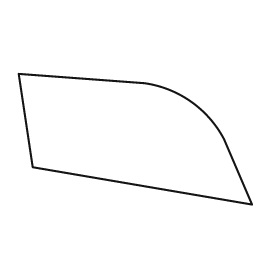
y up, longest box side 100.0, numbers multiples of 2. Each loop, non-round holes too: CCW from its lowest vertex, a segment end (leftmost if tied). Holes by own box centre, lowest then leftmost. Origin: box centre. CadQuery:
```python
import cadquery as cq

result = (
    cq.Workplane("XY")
    .moveTo(50.0, -28.0)
    .lineTo(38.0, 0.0)
    .threePointArc((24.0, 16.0), (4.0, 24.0))
    .lineTo(-50.0, 28.0)
    .lineTo(-44.0, -12.0)
    .close()
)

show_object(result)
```